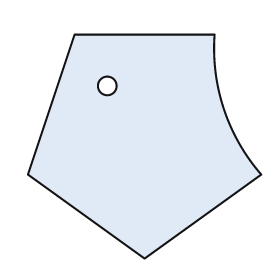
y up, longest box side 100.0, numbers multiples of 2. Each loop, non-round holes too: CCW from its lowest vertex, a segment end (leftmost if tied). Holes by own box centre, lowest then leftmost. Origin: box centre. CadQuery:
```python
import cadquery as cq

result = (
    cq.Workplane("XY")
    .moveTo(0.0, -48.0)
    .lineTo(50.0, -12.0)
    .threePointArc((34.0, 16.0), (30.0, 48.0))
    .lineTo(-30.0, 48.0)
    .lineTo(-50.0, -12.0)
    .close()
    .moveTo(-16.0, 26.0)
    .circle(4.0)
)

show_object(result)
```